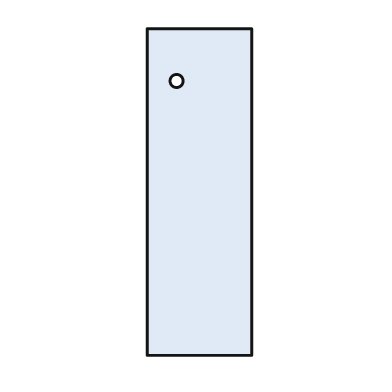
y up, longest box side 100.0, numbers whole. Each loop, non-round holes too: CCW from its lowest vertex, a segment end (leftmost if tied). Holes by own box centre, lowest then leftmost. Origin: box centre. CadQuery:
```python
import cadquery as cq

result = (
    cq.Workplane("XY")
    .moveTo(-16.0, -50.0)
    .lineTo(16.0, -50.0)
    .lineTo(16.0, 50.0)
    .lineTo(-16.0, 50.0)
    .close()
    .moveTo(-7.0, 34.0)
    .circle(2.0)
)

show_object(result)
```